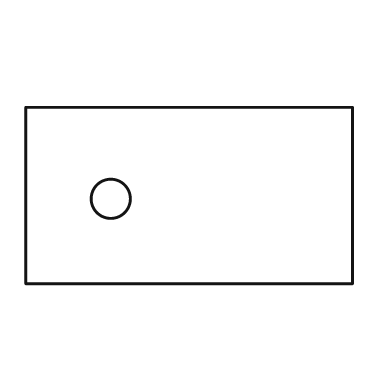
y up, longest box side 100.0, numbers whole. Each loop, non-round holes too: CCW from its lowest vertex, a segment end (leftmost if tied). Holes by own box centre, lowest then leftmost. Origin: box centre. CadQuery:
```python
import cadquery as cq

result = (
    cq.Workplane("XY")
    .moveTo(-50.0, -27.0)
    .lineTo(50.0, -27.0)
    .lineTo(50.0, 27.0)
    .lineTo(-50.0, 27.0)
    .close()
    .moveTo(-24.0, -1.0)
    .circle(6.0)
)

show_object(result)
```